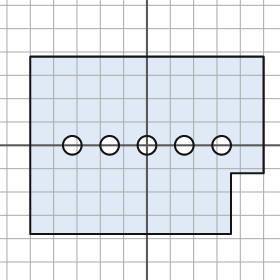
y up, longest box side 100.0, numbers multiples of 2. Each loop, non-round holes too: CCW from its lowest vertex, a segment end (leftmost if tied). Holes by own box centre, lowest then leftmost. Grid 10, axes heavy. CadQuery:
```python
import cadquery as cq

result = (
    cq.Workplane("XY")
    .moveTo(-50.0, -38.0)
    .lineTo(36.0, -38.0)
    .lineTo(36.0, -12.0)
    .lineTo(50.0, -12.0)
    .lineTo(50.0, 38.0)
    .lineTo(-50.0, 38.0)
    .close()
    .moveTo(-32.0, 0.0)
    .circle(4.0)
    .moveTo(-16.0, 0.0)
    .circle(4.0)
    .moveTo(0.0, 0.0)
    .circle(4.0)
    .moveTo(16.0, 0.0)
    .circle(4.0)
    .moveTo(32.0, 0.0)
    .circle(4.0)
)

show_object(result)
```